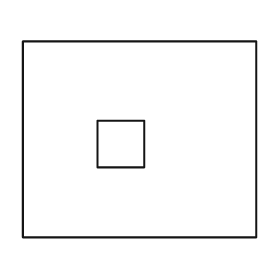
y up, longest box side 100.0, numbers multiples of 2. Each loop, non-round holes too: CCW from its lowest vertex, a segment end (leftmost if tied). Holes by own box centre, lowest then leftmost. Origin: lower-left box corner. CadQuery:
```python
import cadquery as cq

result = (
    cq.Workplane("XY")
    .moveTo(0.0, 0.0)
    .lineTo(100.0, 0.0)
    .lineTo(100.0, 84.0)
    .lineTo(0.0, 84.0)
    .close()
    .moveTo(32.0, 30.0)
    .lineTo(52.0, 30.0)
    .lineTo(52.0, 50.0)
    .lineTo(32.0, 50.0)
    .close()
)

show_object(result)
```